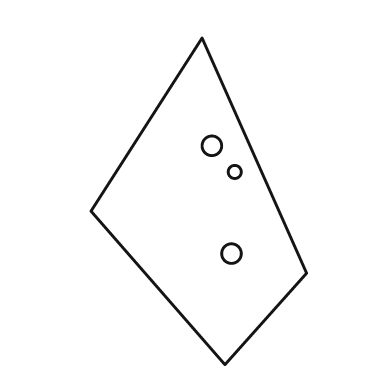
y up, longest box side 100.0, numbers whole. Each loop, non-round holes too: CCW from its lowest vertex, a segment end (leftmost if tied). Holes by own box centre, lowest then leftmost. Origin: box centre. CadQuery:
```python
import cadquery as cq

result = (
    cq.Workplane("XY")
    .moveTo(8.0, -50.0)
    .lineTo(33.0, -22.0)
    .lineTo(1.0, 50.0)
    .lineTo(-33.0, -3.0)
    .close()
    .moveTo(10.0, -16.0)
    .circle(3.0)
    .moveTo(11.0, 9.0)
    .circle(2.0)
    .moveTo(4.0, 17.0)
    .circle(3.0)
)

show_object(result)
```